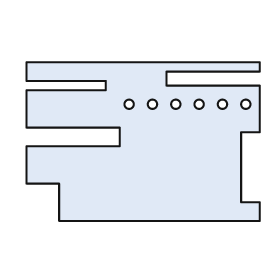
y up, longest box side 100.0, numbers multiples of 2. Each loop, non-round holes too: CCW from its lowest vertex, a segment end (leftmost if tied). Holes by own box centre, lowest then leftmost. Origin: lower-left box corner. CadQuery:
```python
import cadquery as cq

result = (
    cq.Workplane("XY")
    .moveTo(14.0, 0.0)
    .lineTo(100.0, 0.0)
    .lineTo(100.0, 8.0)
    .lineTo(92.0, 8.0)
    .lineTo(92.0, 38.0)
    .lineTo(100.0, 38.0)
    .lineTo(100.0, 58.0)
    .lineTo(60.0, 58.0)
    .lineTo(60.0, 64.0)
    .lineTo(100.0, 64.0)
    .lineTo(100.0, 68.0)
    .lineTo(0.0, 68.0)
    .lineTo(0.0, 60.0)
    .lineTo(34.0, 60.0)
    .lineTo(34.0, 56.0)
    .lineTo(0.0, 56.0)
    .lineTo(0.0, 40.0)
    .lineTo(40.0, 40.0)
    .lineTo(40.0, 32.0)
    .lineTo(0.0, 32.0)
    .lineTo(0.0, 16.0)
    .lineTo(14.0, 16.0)
    .close()
    .moveTo(44.0, 50.0)
    .circle(2.0)
    .moveTo(54.0, 50.0)
    .circle(2.0)
    .moveTo(64.0, 50.0)
    .circle(2.0)
    .moveTo(74.0, 50.0)
    .circle(2.0)
    .moveTo(84.0, 50.0)
    .circle(2.0)
    .moveTo(94.0, 50.0)
    .circle(2.0)
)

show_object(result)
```